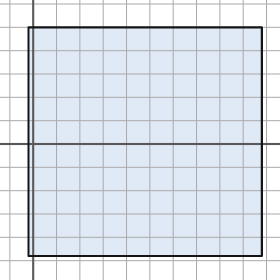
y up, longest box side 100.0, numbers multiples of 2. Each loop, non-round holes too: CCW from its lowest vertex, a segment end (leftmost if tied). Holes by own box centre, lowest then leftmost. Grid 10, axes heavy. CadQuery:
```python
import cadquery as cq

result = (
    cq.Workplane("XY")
    .moveTo(-2.0, -48.0)
    .lineTo(98.0, -48.0)
    .lineTo(98.0, 50.0)
    .lineTo(-2.0, 50.0)
    .close()
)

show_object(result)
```